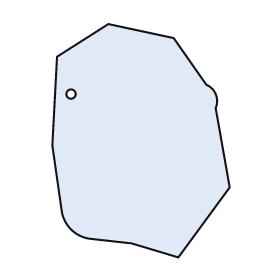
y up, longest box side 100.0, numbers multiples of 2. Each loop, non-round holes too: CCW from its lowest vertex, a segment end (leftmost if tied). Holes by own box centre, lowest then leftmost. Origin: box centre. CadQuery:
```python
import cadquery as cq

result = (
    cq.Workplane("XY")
    .moveTo(16.0, -50.0)
    .lineTo(38.0, -20.0)
    .lineTo(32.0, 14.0)
    .threePointArc((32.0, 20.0), (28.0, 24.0))
    .lineTo(14.0, 44.0)
    .lineTo(-14.0, 50.0)
    .lineTo(-36.0, 36.0)
    .lineTo(-38.0, -2.0)
    .lineTo(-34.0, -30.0)
    .threePointArc((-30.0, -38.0), (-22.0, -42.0))
    .lineTo(-4.0, -44.0)
    .close()
    .moveTo(-30.0, 20.0)
    .circle(2.0)
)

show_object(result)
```